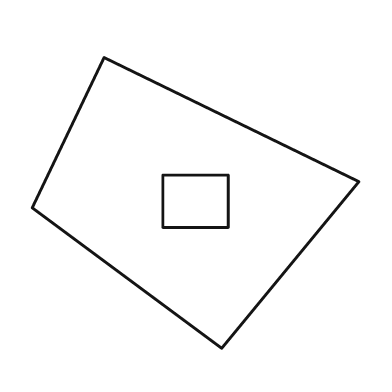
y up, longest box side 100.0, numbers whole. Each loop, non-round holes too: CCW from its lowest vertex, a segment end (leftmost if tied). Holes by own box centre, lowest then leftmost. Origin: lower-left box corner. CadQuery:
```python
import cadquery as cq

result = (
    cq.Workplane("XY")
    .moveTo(58.0, 0.0)
    .lineTo(100.0, 51.0)
    .lineTo(22.0, 89.0)
    .lineTo(0.0, 43.0)
    .close()
    .moveTo(40.0, 37.0)
    .lineTo(60.0, 37.0)
    .lineTo(60.0, 53.0)
    .lineTo(40.0, 53.0)
    .close()
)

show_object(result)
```